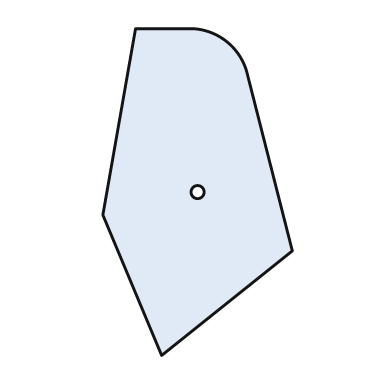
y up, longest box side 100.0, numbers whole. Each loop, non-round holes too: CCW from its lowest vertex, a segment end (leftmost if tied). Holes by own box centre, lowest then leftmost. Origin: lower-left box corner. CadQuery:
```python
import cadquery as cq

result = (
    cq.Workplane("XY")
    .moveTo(18.0, 0.0)
    .lineTo(58.0, 32.0)
    .lineTo(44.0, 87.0)
    .threePointArc((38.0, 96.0), (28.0, 100.0))
    .lineTo(10.0, 100.0)
    .lineTo(0.0, 43.0)
    .close()
    .moveTo(29.0, 50.0)
    .circle(2.0)
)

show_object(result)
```